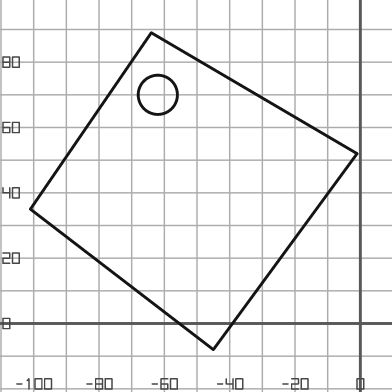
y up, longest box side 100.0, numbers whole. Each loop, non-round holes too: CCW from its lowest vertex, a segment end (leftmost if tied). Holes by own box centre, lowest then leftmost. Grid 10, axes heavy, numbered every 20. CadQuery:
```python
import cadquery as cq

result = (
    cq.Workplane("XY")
    .moveTo(-45.0, -8.0)
    .lineTo(-1.0, 52.0)
    .lineTo(-64.0, 89.0)
    .lineTo(-101.0, 35.0)
    .close()
    .moveTo(-62.0, 70.0)
    .circle(6.0)
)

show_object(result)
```